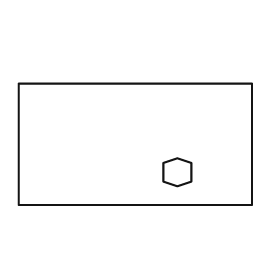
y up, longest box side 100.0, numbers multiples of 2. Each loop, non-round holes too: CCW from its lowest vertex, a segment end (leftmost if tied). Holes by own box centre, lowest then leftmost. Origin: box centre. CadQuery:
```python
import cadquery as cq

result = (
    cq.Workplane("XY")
    .moveTo(-50.0, -26.0)
    .lineTo(50.0, -26.0)
    .lineTo(50.0, 26.0)
    .lineTo(-50.0, 26.0)
    .close()
    .moveTo(18.0, -18.0)
    .lineTo(24.0, -16.0)
    .lineTo(24.0, -8.0)
    .lineTo(18.0, -6.0)
    .lineTo(12.0, -8.0)
    .lineTo(12.0, -16.0)
    .close()
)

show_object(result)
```